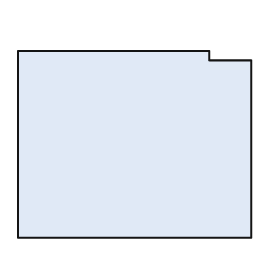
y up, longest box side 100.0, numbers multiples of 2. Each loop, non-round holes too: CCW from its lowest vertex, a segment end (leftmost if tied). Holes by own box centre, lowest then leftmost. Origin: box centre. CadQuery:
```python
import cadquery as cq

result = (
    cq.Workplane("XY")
    .moveTo(-50.0, -40.0)
    .lineTo(50.0, -40.0)
    .lineTo(50.0, 36.0)
    .lineTo(32.0, 36.0)
    .lineTo(32.0, 40.0)
    .lineTo(-50.0, 40.0)
    .close()
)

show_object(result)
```